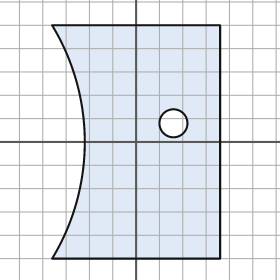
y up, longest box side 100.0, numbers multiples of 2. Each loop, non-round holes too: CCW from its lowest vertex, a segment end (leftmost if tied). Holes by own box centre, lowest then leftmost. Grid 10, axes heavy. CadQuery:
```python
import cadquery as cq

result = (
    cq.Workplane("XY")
    .moveTo(-36.0, -50.0)
    .lineTo(36.0, -50.0)
    .lineTo(36.0, 50.0)
    .lineTo(-36.0, 50.0)
    .threePointArc((-22.0, 0.0), (-36.0, -50.0))
    .close()
    .moveTo(16.0, 8.0)
    .circle(6.0)
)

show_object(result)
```